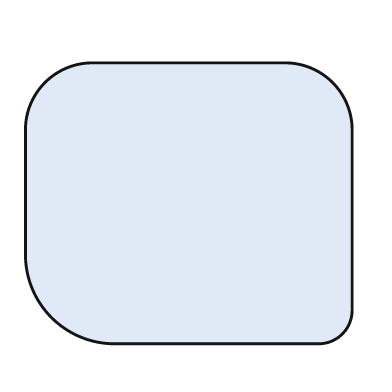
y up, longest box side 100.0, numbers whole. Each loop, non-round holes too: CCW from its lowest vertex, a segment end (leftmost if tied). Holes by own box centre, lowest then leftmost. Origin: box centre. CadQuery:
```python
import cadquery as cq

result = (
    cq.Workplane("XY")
    .moveTo(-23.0, -43.0)
    .lineTo(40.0, -43.0)
    .threePointArc((47.0, -40.0), (50.0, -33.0))
    .lineTo(50.0, 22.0)
    .threePointArc((44.0, 37.0), (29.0, 43.0))
    .lineTo(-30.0, 43.0)
    .threePointArc((-44.0, 37.0), (-50.0, 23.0))
    .lineTo(-50.0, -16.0)
    .threePointArc((-42.0, -35.0), (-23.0, -43.0))
    .close()
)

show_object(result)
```